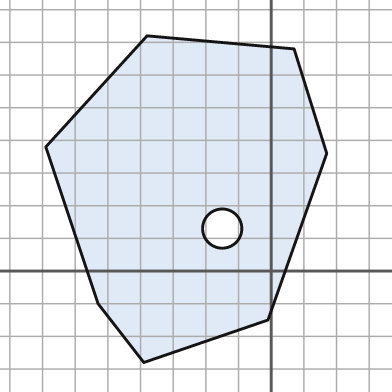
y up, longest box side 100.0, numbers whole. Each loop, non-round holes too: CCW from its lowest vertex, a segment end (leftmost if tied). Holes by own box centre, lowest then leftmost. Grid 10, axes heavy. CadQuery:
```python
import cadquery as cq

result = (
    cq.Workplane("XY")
    .moveTo(-39.0, -28.0)
    .lineTo(-1.0, -15.0)
    .lineTo(17.0, 36.0)
    .lineTo(7.0, 68.0)
    .lineTo(-38.0, 72.0)
    .lineTo(-69.0, 38.0)
    .lineTo(-53.0, -10.0)
    .close()
    .moveTo(-15.0, 13.0)
    .circle(6.0)
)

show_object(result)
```